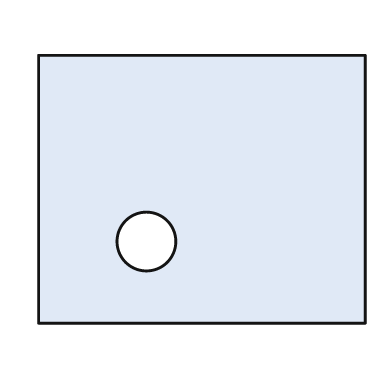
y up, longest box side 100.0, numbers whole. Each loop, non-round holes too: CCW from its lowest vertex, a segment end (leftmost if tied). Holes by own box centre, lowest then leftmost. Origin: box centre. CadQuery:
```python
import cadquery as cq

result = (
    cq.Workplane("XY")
    .moveTo(-50.0, -41.0)
    .lineTo(50.0, -41.0)
    .lineTo(50.0, 41.0)
    .lineTo(-50.0, 41.0)
    .close()
    .moveTo(-17.0, -16.0)
    .circle(9.0)
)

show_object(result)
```